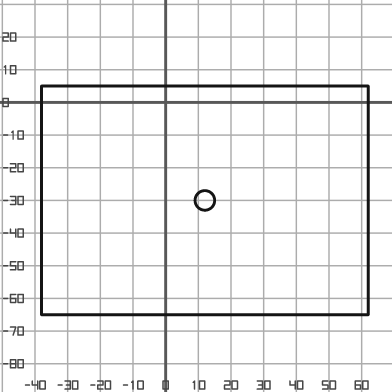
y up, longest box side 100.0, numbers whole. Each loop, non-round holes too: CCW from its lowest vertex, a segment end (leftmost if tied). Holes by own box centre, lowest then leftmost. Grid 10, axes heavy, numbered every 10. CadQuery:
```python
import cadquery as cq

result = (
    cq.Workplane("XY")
    .moveTo(-38.0, -65.0)
    .lineTo(62.0, -65.0)
    .lineTo(62.0, 5.0)
    .lineTo(-38.0, 5.0)
    .close()
    .moveTo(12.0, -30.0)
    .circle(3.0)
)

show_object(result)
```